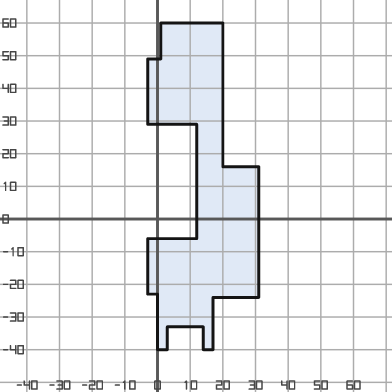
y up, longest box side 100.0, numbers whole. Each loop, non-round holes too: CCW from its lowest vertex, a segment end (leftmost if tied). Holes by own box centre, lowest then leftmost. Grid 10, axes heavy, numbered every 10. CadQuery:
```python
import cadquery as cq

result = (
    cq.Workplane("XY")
    .moveTo(0.0, -40.0)
    .lineTo(3.0, -40.0)
    .lineTo(3.0, -33.0)
    .lineTo(14.0, -33.0)
    .lineTo(14.0, -40.0)
    .lineTo(17.0, -40.0)
    .lineTo(17.0, -24.0)
    .lineTo(31.0, -24.0)
    .lineTo(31.0, 16.0)
    .lineTo(20.0, 16.0)
    .lineTo(20.0, 60.0)
    .lineTo(1.0, 60.0)
    .lineTo(1.0, 49.0)
    .lineTo(-3.0, 49.0)
    .lineTo(-3.0, 29.0)
    .lineTo(12.0, 29.0)
    .lineTo(12.0, -6.0)
    .lineTo(-3.0, -6.0)
    .lineTo(-3.0, -23.0)
    .lineTo(0.0, -23.0)
    .close()
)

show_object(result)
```